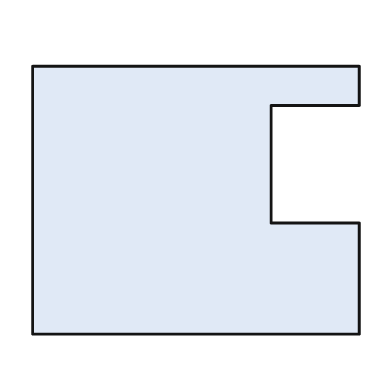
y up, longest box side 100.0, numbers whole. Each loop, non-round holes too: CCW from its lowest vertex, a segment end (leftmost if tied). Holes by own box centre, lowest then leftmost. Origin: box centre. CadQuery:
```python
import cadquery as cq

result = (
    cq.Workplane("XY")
    .moveTo(-50.0, -41.0)
    .lineTo(50.0, -41.0)
    .lineTo(50.0, -7.0)
    .lineTo(23.0, -7.0)
    .lineTo(23.0, 29.0)
    .lineTo(50.0, 29.0)
    .lineTo(50.0, 41.0)
    .lineTo(-50.0, 41.0)
    .close()
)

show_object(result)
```